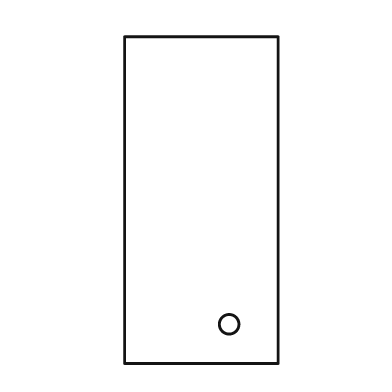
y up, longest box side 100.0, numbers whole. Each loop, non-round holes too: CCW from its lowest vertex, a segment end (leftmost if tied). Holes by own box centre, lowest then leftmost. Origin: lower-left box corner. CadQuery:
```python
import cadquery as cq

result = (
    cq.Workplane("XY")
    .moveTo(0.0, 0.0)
    .lineTo(47.0, 0.0)
    .lineTo(47.0, 100.0)
    .lineTo(0.0, 100.0)
    .close()
    .moveTo(32.0, 12.0)
    .circle(3.0)
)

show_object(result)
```